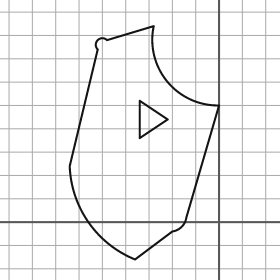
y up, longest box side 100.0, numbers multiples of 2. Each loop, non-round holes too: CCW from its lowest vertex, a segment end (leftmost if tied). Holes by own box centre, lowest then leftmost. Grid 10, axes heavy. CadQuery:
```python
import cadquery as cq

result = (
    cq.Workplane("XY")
    .moveTo(-36.0, -16.0)
    .lineTo(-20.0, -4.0)
    .threePointArc((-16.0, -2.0), (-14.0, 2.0))
    .lineTo(0.0, 50.0)
    .threePointArc((-22.0, 60.0), (-28.0, 84.0))
    .lineTo(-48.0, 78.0)
    .threePointArc((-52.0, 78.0), (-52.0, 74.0))
    .lineTo(-64.0, 24.0)
    .threePointArc((-56.0, 0.0), (-36.0, -16.0))
    .close()
    .moveTo(-34.0, 36.0)
    .lineTo(-22.0, 44.0)
    .lineTo(-34.0, 52.0)
    .close()
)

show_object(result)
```